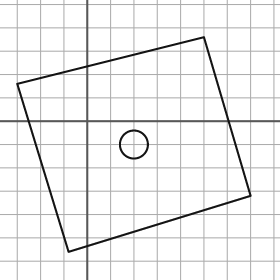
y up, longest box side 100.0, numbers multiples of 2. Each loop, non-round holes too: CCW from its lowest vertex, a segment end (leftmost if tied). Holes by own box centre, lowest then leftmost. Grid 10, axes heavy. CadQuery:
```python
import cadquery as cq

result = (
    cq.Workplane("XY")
    .moveTo(-8.0, -56.0)
    .lineTo(70.0, -32.0)
    .lineTo(50.0, 36.0)
    .lineTo(-30.0, 16.0)
    .close()
    .moveTo(20.0, -10.0)
    .circle(6.0)
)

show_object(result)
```